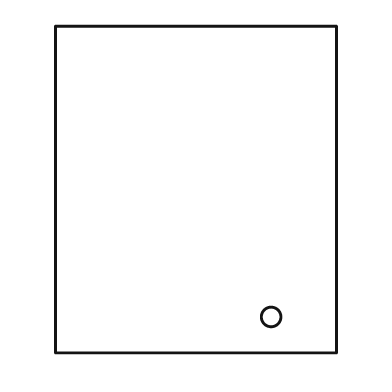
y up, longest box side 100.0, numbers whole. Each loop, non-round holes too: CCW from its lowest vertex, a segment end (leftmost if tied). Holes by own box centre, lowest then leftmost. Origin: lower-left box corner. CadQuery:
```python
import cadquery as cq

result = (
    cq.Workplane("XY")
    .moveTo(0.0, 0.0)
    .lineTo(86.0, 0.0)
    .lineTo(86.0, 100.0)
    .lineTo(0.0, 100.0)
    .close()
    .moveTo(66.0, 11.0)
    .circle(3.0)
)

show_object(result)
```